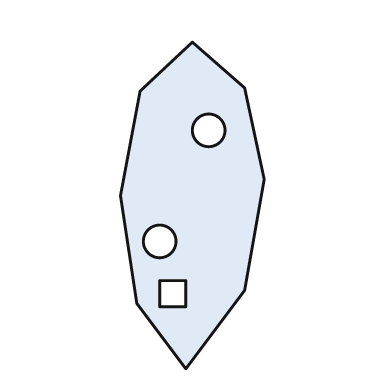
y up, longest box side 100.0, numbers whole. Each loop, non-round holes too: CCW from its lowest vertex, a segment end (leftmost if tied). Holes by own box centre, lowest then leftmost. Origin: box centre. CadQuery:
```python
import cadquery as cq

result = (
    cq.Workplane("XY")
    .moveTo(-2.0, -50.0)
    .lineTo(16.0, -26.0)
    .lineTo(22.0, 8.0)
    .lineTo(16.0, 36.0)
    .lineTo(0.0, 50.0)
    .lineTo(-16.0, 35.0)
    .lineTo(-22.0, 3.0)
    .lineTo(-17.0, -30.0)
    .close()
    .moveTo(-10.0, -31.0)
    .lineTo(-2.0, -31.0)
    .lineTo(-2.0, -23.0)
    .lineTo(-10.0, -23.0)
    .close()
    .moveTo(-10.0, -11.0)
    .circle(5.0)
    .moveTo(5.0, 23.0)
    .circle(5.0)
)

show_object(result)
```